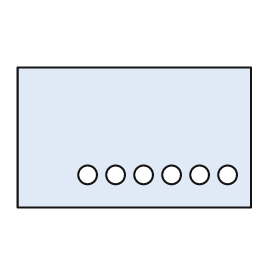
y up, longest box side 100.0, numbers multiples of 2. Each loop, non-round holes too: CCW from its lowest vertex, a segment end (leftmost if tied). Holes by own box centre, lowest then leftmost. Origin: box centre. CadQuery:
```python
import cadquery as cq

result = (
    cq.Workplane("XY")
    .moveTo(-50.0, -30.0)
    .lineTo(50.0, -30.0)
    .lineTo(50.0, 30.0)
    .lineTo(-50.0, 30.0)
    .close()
    .moveTo(-20.0, -16.0)
    .circle(4.0)
    .moveTo(-8.0, -16.0)
    .circle(4.0)
    .moveTo(4.0, -16.0)
    .circle(4.0)
    .moveTo(16.0, -16.0)
    .circle(4.0)
    .moveTo(28.0, -16.0)
    .circle(4.0)
    .moveTo(40.0, -16.0)
    .circle(4.0)
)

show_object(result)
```